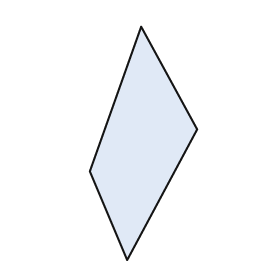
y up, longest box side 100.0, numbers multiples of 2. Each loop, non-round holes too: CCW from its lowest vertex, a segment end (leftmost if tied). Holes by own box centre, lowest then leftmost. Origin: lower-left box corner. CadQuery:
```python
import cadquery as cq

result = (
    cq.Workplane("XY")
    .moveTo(16.0, 0.0)
    .lineTo(46.0, 56.0)
    .lineTo(22.0, 100.0)
    .lineTo(0.0, 38.0)
    .close()
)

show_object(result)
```